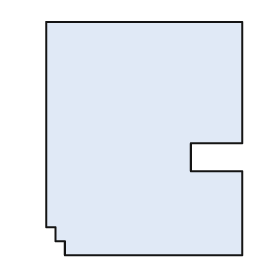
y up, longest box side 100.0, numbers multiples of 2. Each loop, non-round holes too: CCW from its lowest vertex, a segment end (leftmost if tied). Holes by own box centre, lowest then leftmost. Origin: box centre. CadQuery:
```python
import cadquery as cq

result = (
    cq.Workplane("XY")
    .moveTo(-34.0, -50.0)
    .lineTo(42.0, -50.0)
    .lineTo(42.0, -14.0)
    .lineTo(20.0, -14.0)
    .lineTo(20.0, -2.0)
    .lineTo(42.0, -2.0)
    .lineTo(42.0, 50.0)
    .lineTo(-42.0, 50.0)
    .lineTo(-42.0, -38.0)
    .lineTo(-38.0, -38.0)
    .lineTo(-38.0, -44.0)
    .lineTo(-34.0, -44.0)
    .close()
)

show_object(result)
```